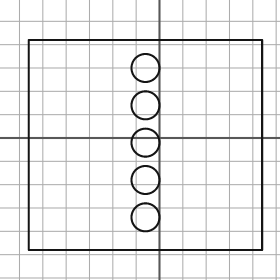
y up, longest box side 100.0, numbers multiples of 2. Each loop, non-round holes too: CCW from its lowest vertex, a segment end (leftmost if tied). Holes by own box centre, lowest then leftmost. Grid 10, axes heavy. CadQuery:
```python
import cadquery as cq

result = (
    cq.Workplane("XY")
    .moveTo(-56.0, -48.0)
    .lineTo(44.0, -48.0)
    .lineTo(44.0, 42.0)
    .lineTo(-56.0, 42.0)
    .close()
    .moveTo(-6.0, -34.0)
    .circle(6.0)
    .moveTo(-6.0, -18.0)
    .circle(6.0)
    .moveTo(-6.0, -2.0)
    .circle(6.0)
    .moveTo(-6.0, 14.0)
    .circle(6.0)
    .moveTo(-6.0, 30.0)
    .circle(6.0)
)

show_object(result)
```